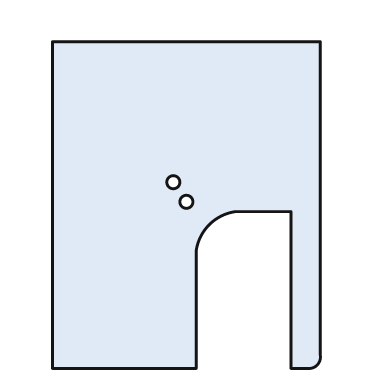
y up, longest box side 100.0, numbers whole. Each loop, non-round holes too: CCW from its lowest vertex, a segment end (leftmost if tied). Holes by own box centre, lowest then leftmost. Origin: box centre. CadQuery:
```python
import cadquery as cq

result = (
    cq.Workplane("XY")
    .moveTo(-41.0, -50.0)
    .lineTo(3.0, -50.0)
    .lineTo(3.0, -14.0)
    .threePointArc((7.0, -6.0), (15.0, -2.0))
    .lineTo(32.0, -2.0)
    .lineTo(32.0, -50.0)
    .lineTo(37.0, -50.0)
    .threePointArc((40.0, -49.0), (41.0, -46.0))
    .lineTo(41.0, 50.0)
    .lineTo(-41.0, 50.0)
    .close()
    .moveTo(0.0, 1.0)
    .circle(2.0)
    .moveTo(-4.0, 7.0)
    .circle(2.0)
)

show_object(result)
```